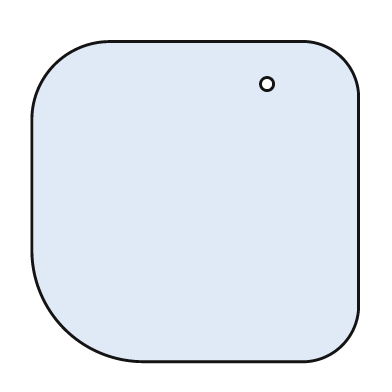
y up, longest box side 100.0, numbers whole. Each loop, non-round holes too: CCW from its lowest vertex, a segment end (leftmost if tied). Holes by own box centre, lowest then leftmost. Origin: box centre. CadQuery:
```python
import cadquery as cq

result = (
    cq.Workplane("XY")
    .moveTo(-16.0, -49.0)
    .lineTo(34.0, -49.0)
    .threePointArc((45.0, -44.0), (50.0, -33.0))
    .lineTo(50.0, 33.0)
    .threePointArc((45.0, 44.0), (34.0, 49.0))
    .lineTo(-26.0, 49.0)
    .threePointArc((-43.0, 42.0), (-50.0, 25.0))
    .lineTo(-50.0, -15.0)
    .threePointArc((-40.0, -39.0), (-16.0, -49.0))
    .close()
    .moveTo(22.0, 36.0)
    .circle(2.0)
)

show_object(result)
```